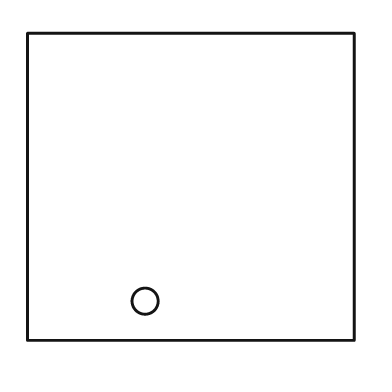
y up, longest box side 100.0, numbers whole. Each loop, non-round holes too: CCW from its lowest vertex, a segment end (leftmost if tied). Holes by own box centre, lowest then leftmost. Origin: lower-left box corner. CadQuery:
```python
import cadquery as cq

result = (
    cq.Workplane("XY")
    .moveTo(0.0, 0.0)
    .lineTo(100.0, 0.0)
    .lineTo(100.0, 94.0)
    .lineTo(0.0, 94.0)
    .close()
    .moveTo(36.0, 12.0)
    .circle(4.0)
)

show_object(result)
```